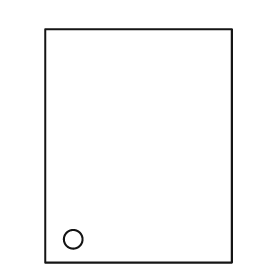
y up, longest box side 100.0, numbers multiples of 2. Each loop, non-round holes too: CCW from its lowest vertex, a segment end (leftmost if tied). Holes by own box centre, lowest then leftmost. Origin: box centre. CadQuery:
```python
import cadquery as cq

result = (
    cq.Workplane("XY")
    .moveTo(-40.0, -50.0)
    .lineTo(40.0, -50.0)
    .lineTo(40.0, 50.0)
    .lineTo(-40.0, 50.0)
    .close()
    .moveTo(-28.0, -40.0)
    .circle(4.0)
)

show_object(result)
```